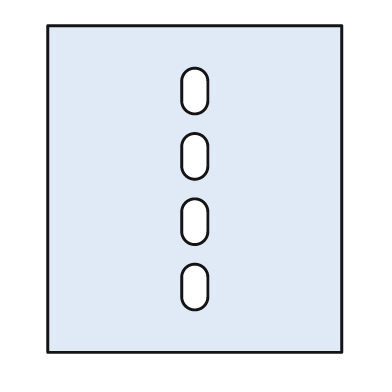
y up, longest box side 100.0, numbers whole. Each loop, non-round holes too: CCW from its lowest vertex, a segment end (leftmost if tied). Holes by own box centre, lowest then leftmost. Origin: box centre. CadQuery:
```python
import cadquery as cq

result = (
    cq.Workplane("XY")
    .moveTo(-45.0, -50.0)
    .lineTo(45.0, -50.0)
    .lineTo(45.0, 50.0)
    .lineTo(-45.0, 50.0)
    .close()
    .moveTo(-4.0, -33.0)
    .threePointArc((0.0, -37.0), (4.0, -33.0))
    .lineTo(4.0, -27.0)
    .threePointArc((0.0, -23.0), (-4.0, -27.0))
    .close()
    .moveTo(-4.0, -13.0)
    .threePointArc((0.0, -17.0), (4.0, -13.0))
    .lineTo(4.0, -7.0)
    .threePointArc((0.0, -3.0), (-4.0, -7.0))
    .close()
    .moveTo(-4.0, 7.0)
    .threePointArc((0.0, 3.0), (4.0, 7.0))
    .lineTo(4.0, 13.0)
    .threePointArc((0.0, 17.0), (-4.0, 13.0))
    .close()
    .moveTo(-4.0, 27.0)
    .threePointArc((0.0, 23.0), (4.0, 27.0))
    .lineTo(4.0, 33.0)
    .threePointArc((0.0, 37.0), (-4.0, 33.0))
    .close()
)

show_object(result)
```